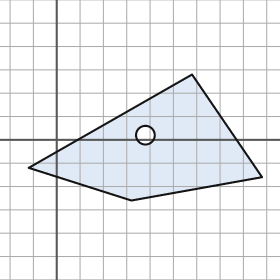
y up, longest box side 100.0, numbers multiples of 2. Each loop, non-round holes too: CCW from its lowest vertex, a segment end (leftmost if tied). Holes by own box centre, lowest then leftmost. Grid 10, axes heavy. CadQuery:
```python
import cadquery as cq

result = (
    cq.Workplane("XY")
    .moveTo(32.0, -26.0)
    .lineTo(88.0, -16.0)
    .lineTo(58.0, 28.0)
    .lineTo(-12.0, -12.0)
    .close()
    .moveTo(38.0, 2.0)
    .circle(4.0)
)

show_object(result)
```